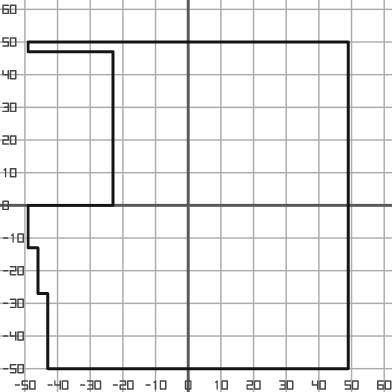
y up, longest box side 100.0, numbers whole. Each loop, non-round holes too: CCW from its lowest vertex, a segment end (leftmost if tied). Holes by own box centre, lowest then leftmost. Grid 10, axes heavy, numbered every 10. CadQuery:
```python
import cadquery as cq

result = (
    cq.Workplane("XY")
    .moveTo(-43.0, -50.0)
    .lineTo(49.0, -50.0)
    .lineTo(49.0, 50.0)
    .lineTo(-49.0, 50.0)
    .lineTo(-49.0, 47.0)
    .lineTo(-23.0, 47.0)
    .lineTo(-23.0, 0.0)
    .lineTo(-49.0, 0.0)
    .lineTo(-49.0, -13.0)
    .lineTo(-46.0, -13.0)
    .lineTo(-46.0, -27.0)
    .lineTo(-43.0, -27.0)
    .close()
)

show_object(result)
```